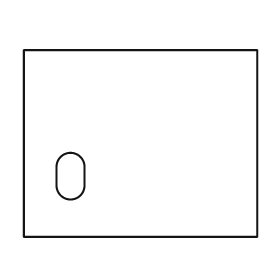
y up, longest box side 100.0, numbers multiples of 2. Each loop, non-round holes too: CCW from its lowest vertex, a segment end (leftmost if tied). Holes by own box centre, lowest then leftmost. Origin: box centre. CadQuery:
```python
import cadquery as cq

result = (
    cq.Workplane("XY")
    .moveTo(-50.0, -40.0)
    .lineTo(50.0, -40.0)
    .lineTo(50.0, 40.0)
    .lineTo(-50.0, 40.0)
    .close()
    .moveTo(-36.0, -18.0)
    .threePointArc((-30.0, -24.0), (-24.0, -18.0))
    .lineTo(-24.0, -10.0)
    .threePointArc((-30.0, -4.0), (-36.0, -10.0))
    .close()
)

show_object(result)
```